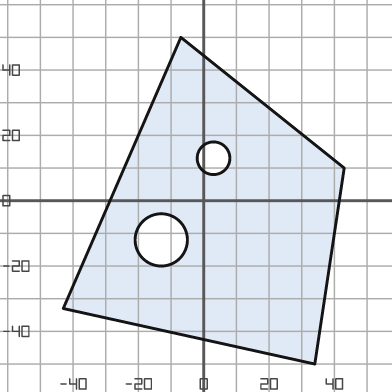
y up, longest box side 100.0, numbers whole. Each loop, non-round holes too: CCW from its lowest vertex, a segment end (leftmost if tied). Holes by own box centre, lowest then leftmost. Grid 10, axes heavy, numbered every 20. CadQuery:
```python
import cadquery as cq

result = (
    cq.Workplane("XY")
    .moveTo(34.0, -50.0)
    .lineTo(43.0, 10.0)
    .lineTo(-7.0, 50.0)
    .lineTo(-43.0, -33.0)
    .close()
    .moveTo(-13.0, -12.0)
    .circle(8.0)
    .moveTo(3.0, 13.0)
    .circle(5.0)
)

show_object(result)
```